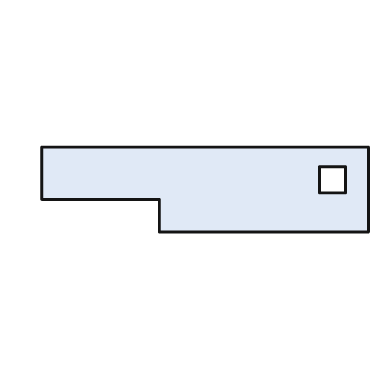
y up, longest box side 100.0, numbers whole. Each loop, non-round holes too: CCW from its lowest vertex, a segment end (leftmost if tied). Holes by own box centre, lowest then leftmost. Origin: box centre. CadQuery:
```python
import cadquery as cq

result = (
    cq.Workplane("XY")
    .moveTo(-14.0, -13.0)
    .lineTo(50.0, -13.0)
    .lineTo(50.0, 13.0)
    .lineTo(-50.0, 13.0)
    .lineTo(-50.0, -3.0)
    .lineTo(-14.0, -3.0)
    .close()
    .moveTo(35.0, -1.0)
    .lineTo(43.0, -1.0)
    .lineTo(43.0, 7.0)
    .lineTo(35.0, 7.0)
    .close()
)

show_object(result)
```